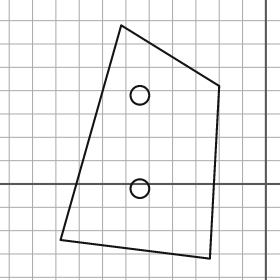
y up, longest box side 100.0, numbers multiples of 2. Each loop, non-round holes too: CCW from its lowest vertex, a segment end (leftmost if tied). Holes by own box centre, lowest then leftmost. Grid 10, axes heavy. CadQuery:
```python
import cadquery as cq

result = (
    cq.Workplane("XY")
    .moveTo(-24.0, -32.0)
    .lineTo(-20.0, 42.0)
    .lineTo(-62.0, 68.0)
    .lineTo(-88.0, -24.0)
    .close()
    .moveTo(-54.0, -2.0)
    .circle(4.0)
    .moveTo(-54.0, 38.0)
    .circle(4.0)
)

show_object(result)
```